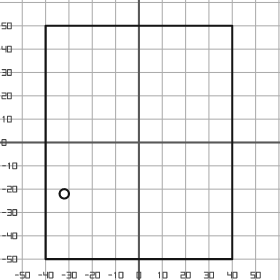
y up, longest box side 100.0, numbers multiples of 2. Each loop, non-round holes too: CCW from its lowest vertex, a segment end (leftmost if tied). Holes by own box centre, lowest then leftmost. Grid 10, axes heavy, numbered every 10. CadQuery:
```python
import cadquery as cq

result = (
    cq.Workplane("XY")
    .moveTo(-40.0, -50.0)
    .lineTo(40.0, -50.0)
    .lineTo(40.0, 50.0)
    .lineTo(-40.0, 50.0)
    .close()
    .moveTo(-32.0, -22.0)
    .circle(2.0)
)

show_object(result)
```